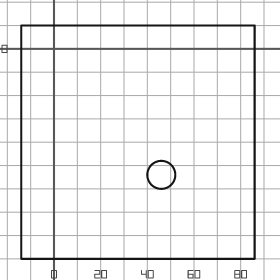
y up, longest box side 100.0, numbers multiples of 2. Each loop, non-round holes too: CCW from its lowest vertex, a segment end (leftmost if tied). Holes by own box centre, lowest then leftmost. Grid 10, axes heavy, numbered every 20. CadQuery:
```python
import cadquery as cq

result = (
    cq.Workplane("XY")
    .moveTo(-14.0, -90.0)
    .lineTo(86.0, -90.0)
    .lineTo(86.0, 10.0)
    .lineTo(-14.0, 10.0)
    .close()
    .moveTo(46.0, -54.0)
    .circle(6.0)
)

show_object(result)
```